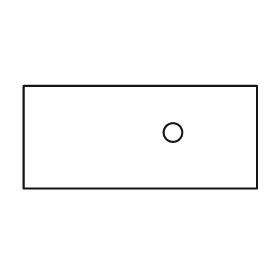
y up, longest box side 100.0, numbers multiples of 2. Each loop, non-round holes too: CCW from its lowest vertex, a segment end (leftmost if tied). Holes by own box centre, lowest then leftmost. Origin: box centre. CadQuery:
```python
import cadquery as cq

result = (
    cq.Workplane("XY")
    .moveTo(-50.0, -22.0)
    .lineTo(50.0, -22.0)
    .lineTo(50.0, 22.0)
    .lineTo(-50.0, 22.0)
    .close()
    .moveTo(14.0, 2.0)
    .circle(4.0)
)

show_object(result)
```